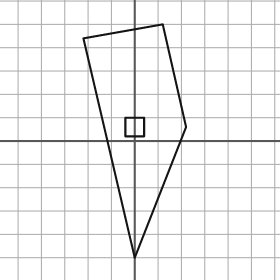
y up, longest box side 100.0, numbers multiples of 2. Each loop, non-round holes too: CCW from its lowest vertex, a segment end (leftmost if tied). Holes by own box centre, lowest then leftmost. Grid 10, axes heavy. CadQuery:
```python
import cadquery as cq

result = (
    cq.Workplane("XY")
    .moveTo(0.0, -50.0)
    .lineTo(22.0, 6.0)
    .lineTo(12.0, 50.0)
    .lineTo(-22.0, 44.0)
    .close()
    .moveTo(-4.0, 2.0)
    .lineTo(4.0, 2.0)
    .lineTo(4.0, 10.0)
    .lineTo(-4.0, 10.0)
    .close()
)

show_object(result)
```